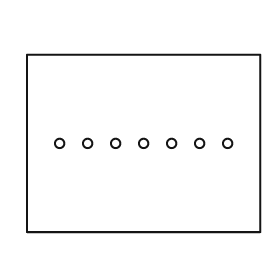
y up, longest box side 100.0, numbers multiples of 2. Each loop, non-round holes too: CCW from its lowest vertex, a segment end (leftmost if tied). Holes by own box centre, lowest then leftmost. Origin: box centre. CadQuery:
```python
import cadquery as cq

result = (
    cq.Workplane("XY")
    .moveTo(-50.0, -38.0)
    .lineTo(50.0, -38.0)
    .lineTo(50.0, 38.0)
    .lineTo(-50.0, 38.0)
    .close()
    .moveTo(-36.0, 0.0)
    .circle(2.0)
    .moveTo(-24.0, 0.0)
    .circle(2.0)
    .moveTo(-12.0, 0.0)
    .circle(2.0)
    .moveTo(0.0, 0.0)
    .circle(2.0)
    .moveTo(12.0, 0.0)
    .circle(2.0)
    .moveTo(24.0, 0.0)
    .circle(2.0)
    .moveTo(36.0, 0.0)
    .circle(2.0)
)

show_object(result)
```